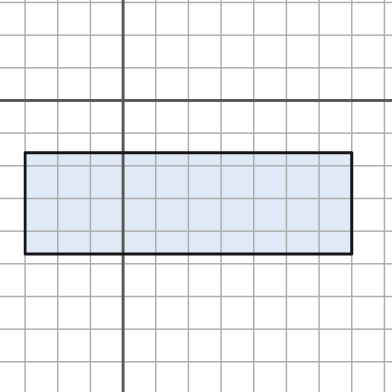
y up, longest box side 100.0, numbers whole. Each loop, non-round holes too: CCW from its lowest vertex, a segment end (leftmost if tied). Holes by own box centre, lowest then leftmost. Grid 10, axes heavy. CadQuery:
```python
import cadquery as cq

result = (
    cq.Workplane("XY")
    .moveTo(-30.0, -47.0)
    .lineTo(70.0, -47.0)
    .lineTo(70.0, -16.0)
    .lineTo(-30.0, -16.0)
    .close()
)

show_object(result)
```